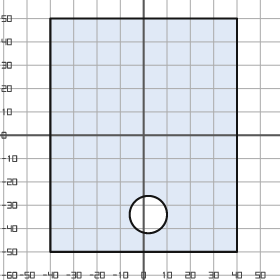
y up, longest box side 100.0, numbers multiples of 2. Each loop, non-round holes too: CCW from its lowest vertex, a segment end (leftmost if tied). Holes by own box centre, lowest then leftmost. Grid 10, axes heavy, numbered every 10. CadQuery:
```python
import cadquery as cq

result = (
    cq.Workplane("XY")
    .moveTo(-40.0, -50.0)
    .lineTo(40.0, -50.0)
    .lineTo(40.0, 50.0)
    .lineTo(-40.0, 50.0)
    .close()
    .moveTo(2.0, -34.0)
    .circle(8.0)
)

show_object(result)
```